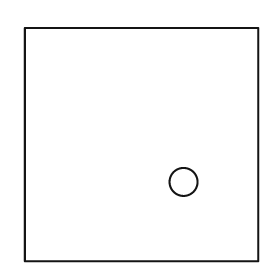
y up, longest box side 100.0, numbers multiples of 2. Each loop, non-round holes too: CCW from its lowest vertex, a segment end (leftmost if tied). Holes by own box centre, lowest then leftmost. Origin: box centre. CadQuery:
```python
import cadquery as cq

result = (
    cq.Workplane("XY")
    .moveTo(-50.0, -50.0)
    .lineTo(50.0, -50.0)
    .lineTo(50.0, 50.0)
    .lineTo(-50.0, 50.0)
    .close()
    .moveTo(18.0, -16.0)
    .circle(6.0)
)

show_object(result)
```